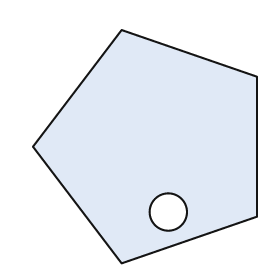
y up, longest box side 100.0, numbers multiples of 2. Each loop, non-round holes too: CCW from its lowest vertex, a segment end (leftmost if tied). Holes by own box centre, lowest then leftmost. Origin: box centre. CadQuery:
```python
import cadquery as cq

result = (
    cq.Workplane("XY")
    .moveTo(-10.0, -50.0)
    .lineTo(48.0, -30.0)
    .lineTo(48.0, 30.0)
    .lineTo(-10.0, 50.0)
    .lineTo(-48.0, 0.0)
    .close()
    .moveTo(10.0, -28.0)
    .circle(8.0)
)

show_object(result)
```